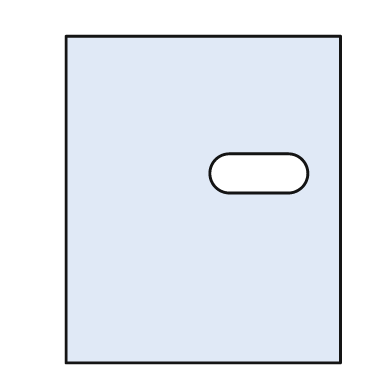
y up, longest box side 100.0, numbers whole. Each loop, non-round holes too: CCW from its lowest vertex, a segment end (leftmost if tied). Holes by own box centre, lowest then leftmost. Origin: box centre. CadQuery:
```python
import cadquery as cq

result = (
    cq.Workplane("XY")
    .moveTo(-42.0, -50.0)
    .lineTo(42.0, -50.0)
    .lineTo(42.0, 50.0)
    .lineTo(-42.0, 50.0)
    .close()
    .moveTo(8.0, 2.0)
    .lineTo(26.0, 2.0)
    .threePointArc((32.0, 8.0), (26.0, 14.0))
    .lineTo(8.0, 14.0)
    .threePointArc((2.0, 8.0), (8.0, 2.0))
    .close()
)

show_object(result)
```